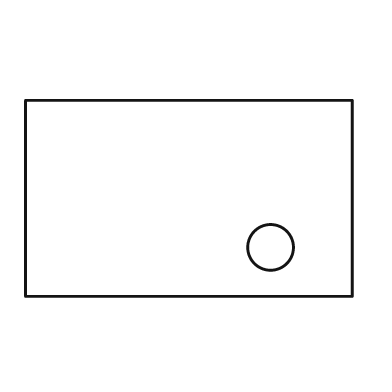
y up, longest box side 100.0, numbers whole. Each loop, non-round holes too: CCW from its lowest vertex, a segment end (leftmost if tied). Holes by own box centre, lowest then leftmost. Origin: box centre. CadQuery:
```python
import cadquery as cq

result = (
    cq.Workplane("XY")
    .moveTo(-50.0, -30.0)
    .lineTo(50.0, -30.0)
    .lineTo(50.0, 30.0)
    .lineTo(-50.0, 30.0)
    .close()
    .moveTo(25.0, -15.0)
    .circle(7.0)
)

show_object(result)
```